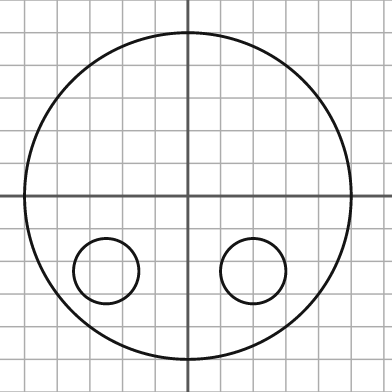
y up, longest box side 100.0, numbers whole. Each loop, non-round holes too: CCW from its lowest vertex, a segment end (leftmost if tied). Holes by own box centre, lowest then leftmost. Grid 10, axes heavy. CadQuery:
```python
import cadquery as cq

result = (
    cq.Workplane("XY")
    .moveTo(0.0, 0.0)
    .circle(50.0)
    .moveTo(-25.0, -23.0)
    .circle(10.0)
    .moveTo(20.0, -23.0)
    .circle(10.0)
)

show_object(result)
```